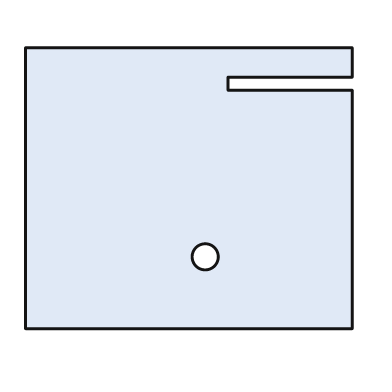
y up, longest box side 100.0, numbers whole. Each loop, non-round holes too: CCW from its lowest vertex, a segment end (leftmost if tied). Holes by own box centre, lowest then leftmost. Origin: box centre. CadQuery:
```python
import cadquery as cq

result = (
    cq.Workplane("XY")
    .moveTo(-50.0, -43.0)
    .lineTo(50.0, -43.0)
    .lineTo(50.0, 30.0)
    .lineTo(12.0, 30.0)
    .lineTo(12.0, 34.0)
    .lineTo(50.0, 34.0)
    .lineTo(50.0, 43.0)
    .lineTo(-50.0, 43.0)
    .close()
    .moveTo(5.0, -21.0)
    .circle(4.0)
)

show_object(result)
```